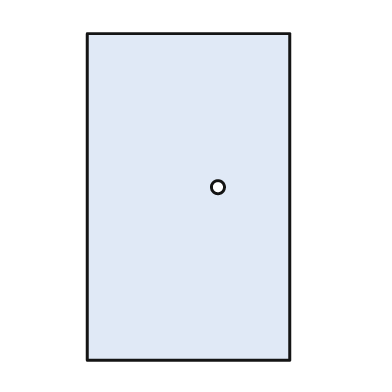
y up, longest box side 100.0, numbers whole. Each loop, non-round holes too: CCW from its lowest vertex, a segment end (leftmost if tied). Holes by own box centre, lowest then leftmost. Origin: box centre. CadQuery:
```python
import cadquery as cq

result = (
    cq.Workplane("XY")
    .moveTo(-31.0, -50.0)
    .lineTo(31.0, -50.0)
    .lineTo(31.0, 50.0)
    .lineTo(-31.0, 50.0)
    .close()
    .moveTo(9.0, 3.0)
    .circle(2.0)
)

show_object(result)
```